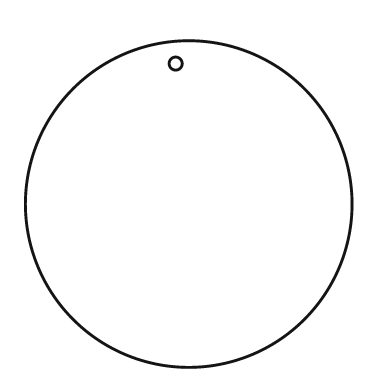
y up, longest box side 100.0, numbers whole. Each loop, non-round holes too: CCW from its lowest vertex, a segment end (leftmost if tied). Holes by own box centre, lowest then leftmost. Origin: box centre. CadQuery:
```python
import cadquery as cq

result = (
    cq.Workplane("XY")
    .moveTo(0.0, 0.0)
    .circle(50.0)
    .moveTo(-4.0, 43.0)
    .circle(2.0)
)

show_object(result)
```